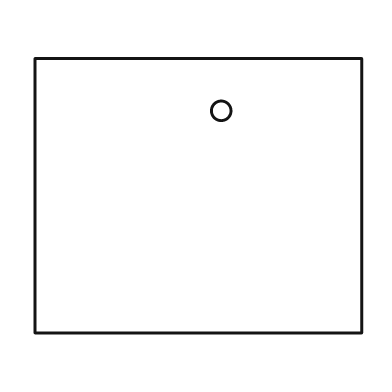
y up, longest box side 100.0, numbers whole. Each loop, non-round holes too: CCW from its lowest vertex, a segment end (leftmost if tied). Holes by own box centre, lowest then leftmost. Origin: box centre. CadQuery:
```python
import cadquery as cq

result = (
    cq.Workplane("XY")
    .moveTo(-50.0, -42.0)
    .lineTo(50.0, -42.0)
    .lineTo(50.0, 42.0)
    .lineTo(-50.0, 42.0)
    .close()
    .moveTo(7.0, 26.0)
    .circle(3.0)
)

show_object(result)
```